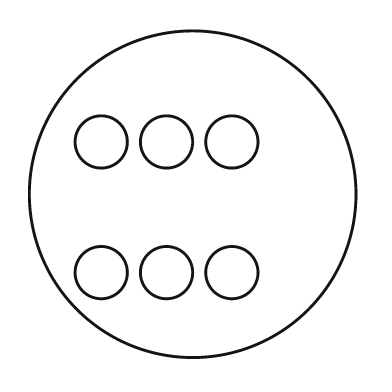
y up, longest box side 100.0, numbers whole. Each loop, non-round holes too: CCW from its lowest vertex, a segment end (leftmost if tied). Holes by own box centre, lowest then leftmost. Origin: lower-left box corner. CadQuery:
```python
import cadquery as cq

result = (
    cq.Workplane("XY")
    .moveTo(50.0, 50.0)
    .circle(50.0)
    .moveTo(22.0, 26.0)
    .circle(8.0)
    .moveTo(42.0, 26.0)
    .circle(8.0)
    .moveTo(62.0, 26.0)
    .circle(8.0)
    .moveTo(22.0, 66.0)
    .circle(8.0)
    .moveTo(42.0, 66.0)
    .circle(8.0)
    .moveTo(62.0, 66.0)
    .circle(8.0)
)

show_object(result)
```